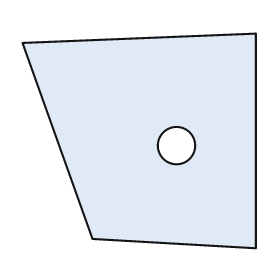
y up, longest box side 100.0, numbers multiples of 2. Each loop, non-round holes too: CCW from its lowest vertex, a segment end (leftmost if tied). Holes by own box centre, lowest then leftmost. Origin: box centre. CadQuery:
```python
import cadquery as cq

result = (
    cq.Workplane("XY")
    .moveTo(50.0, -46.0)
    .lineTo(50.0, 46.0)
    .lineTo(-50.0, 42.0)
    .lineTo(-20.0, -42.0)
    .close()
    .moveTo(16.0, -2.0)
    .circle(8.0)
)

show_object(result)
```